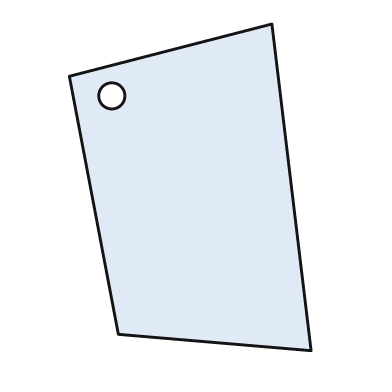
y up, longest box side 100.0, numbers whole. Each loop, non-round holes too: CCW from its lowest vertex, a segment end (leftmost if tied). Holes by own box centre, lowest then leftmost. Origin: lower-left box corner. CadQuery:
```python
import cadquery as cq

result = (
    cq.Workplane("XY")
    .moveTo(74.0, 0.0)
    .lineTo(62.0, 100.0)
    .lineTo(0.0, 84.0)
    .lineTo(15.0, 5.0)
    .close()
    .moveTo(13.0, 78.0)
    .circle(4.0)
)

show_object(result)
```